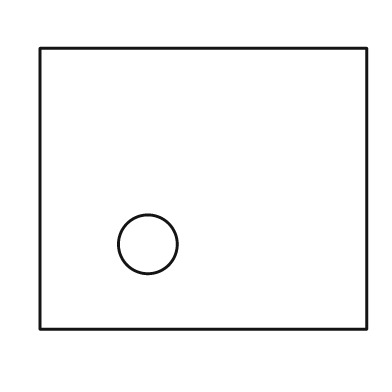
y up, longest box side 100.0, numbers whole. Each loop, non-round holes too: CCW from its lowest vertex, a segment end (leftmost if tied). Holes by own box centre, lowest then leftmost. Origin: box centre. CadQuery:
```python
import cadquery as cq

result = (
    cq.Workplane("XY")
    .moveTo(-50.0, -43.0)
    .lineTo(50.0, -43.0)
    .lineTo(50.0, 43.0)
    .lineTo(-50.0, 43.0)
    .close()
    .moveTo(-17.0, -17.0)
    .circle(9.0)
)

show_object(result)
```